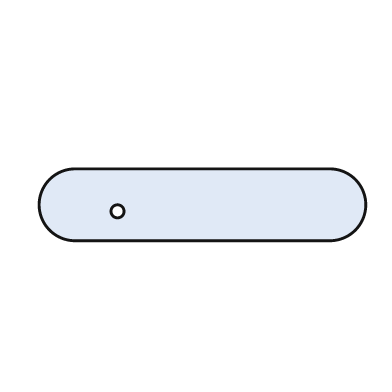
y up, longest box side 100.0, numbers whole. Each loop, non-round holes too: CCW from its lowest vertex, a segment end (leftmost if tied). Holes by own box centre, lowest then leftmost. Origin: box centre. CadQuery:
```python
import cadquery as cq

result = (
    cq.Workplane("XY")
    .moveTo(-39.0, -11.0)
    .lineTo(39.0, -11.0)
    .threePointArc((50.0, 0.0), (39.0, 11.0))
    .lineTo(-39.0, 11.0)
    .threePointArc((-50.0, 0.0), (-39.0, -11.0))
    .close()
    .moveTo(-26.0, -2.0)
    .circle(2.0)
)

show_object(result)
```